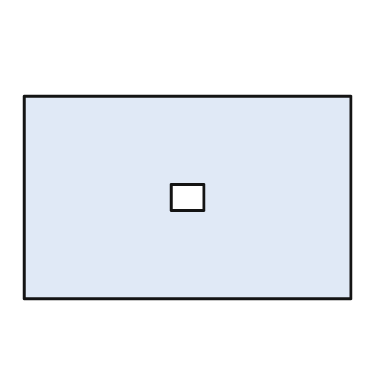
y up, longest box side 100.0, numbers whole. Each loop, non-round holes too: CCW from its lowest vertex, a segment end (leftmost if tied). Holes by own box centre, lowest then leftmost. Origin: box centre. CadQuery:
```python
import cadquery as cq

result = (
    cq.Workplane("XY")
    .moveTo(-50.0, -31.0)
    .lineTo(50.0, -31.0)
    .lineTo(50.0, 31.0)
    .lineTo(-50.0, 31.0)
    .close()
    .moveTo(-5.0, -4.0)
    .lineTo(5.0, -4.0)
    .lineTo(5.0, 4.0)
    .lineTo(-5.0, 4.0)
    .close()
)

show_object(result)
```